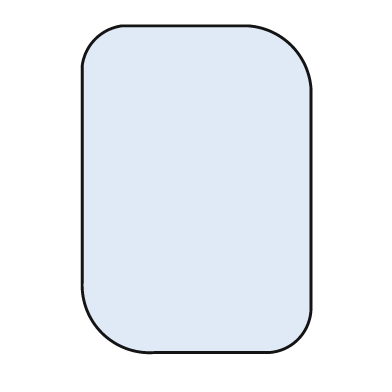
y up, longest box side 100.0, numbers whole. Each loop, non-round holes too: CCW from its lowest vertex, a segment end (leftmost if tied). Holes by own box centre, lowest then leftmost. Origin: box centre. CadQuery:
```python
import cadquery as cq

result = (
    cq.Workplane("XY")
    .moveTo(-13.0, -50.0)
    .lineTo(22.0, -50.0)
    .threePointArc((31.0, -46.0), (35.0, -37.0))
    .lineTo(35.0, 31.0)
    .threePointArc((29.0, 44.0), (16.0, 50.0))
    .lineTo(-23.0, 50.0)
    .threePointArc((-31.0, 46.0), (-35.0, 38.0))
    .lineTo(-35.0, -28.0)
    .threePointArc((-29.0, -44.0), (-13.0, -50.0))
    .close()
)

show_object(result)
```